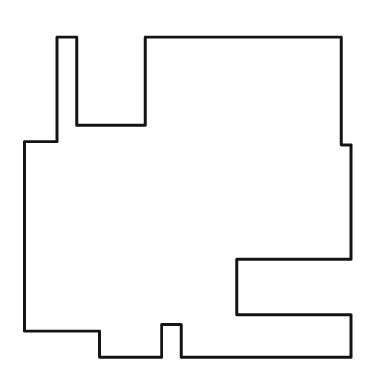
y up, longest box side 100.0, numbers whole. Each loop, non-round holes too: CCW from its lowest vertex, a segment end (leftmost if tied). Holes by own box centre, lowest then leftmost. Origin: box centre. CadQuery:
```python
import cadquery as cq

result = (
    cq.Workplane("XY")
    .moveTo(-27.0, -49.0)
    .lineTo(-8.0, -49.0)
    .lineTo(-8.0, -39.0)
    .lineTo(-2.0, -39.0)
    .lineTo(-2.0, -49.0)
    .lineTo(50.0, -49.0)
    .lineTo(50.0, -36.0)
    .lineTo(15.0, -36.0)
    .lineTo(15.0, -19.0)
    .lineTo(50.0, -19.0)
    .lineTo(50.0, 16.0)
    .lineTo(47.0, 16.0)
    .lineTo(47.0, 49.0)
    .lineTo(-13.0, 49.0)
    .lineTo(-13.0, 22.0)
    .lineTo(-34.0, 22.0)
    .lineTo(-34.0, 49.0)
    .lineTo(-40.0, 49.0)
    .lineTo(-40.0, 17.0)
    .lineTo(-50.0, 17.0)
    .lineTo(-50.0, -41.0)
    .lineTo(-27.0, -41.0)
    .close()
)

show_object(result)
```